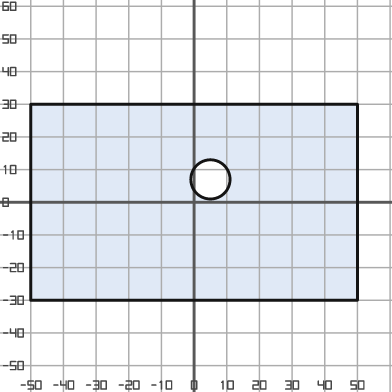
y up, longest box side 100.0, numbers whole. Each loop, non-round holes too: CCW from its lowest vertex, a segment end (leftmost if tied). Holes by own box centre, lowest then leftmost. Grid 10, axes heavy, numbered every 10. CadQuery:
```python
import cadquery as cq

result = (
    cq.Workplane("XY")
    .moveTo(-50.0, -30.0)
    .lineTo(50.0, -30.0)
    .lineTo(50.0, 30.0)
    .lineTo(-50.0, 30.0)
    .close()
    .moveTo(5.0, 7.0)
    .circle(6.0)
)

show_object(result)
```